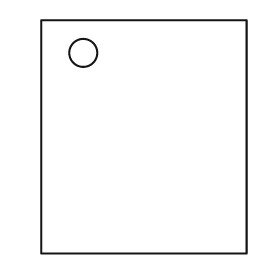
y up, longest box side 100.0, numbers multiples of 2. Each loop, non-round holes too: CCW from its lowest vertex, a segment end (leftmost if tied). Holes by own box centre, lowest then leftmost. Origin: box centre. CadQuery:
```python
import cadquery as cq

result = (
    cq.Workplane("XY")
    .moveTo(-44.0, -50.0)
    .lineTo(44.0, -50.0)
    .lineTo(44.0, 50.0)
    .lineTo(-44.0, 50.0)
    .close()
    .moveTo(-26.0, 36.0)
    .circle(6.0)
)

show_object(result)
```